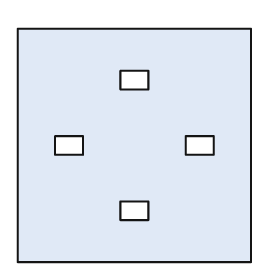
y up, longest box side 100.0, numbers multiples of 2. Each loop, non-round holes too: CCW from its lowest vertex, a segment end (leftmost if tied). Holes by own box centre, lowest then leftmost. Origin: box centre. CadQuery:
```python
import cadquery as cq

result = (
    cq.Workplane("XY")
    .moveTo(-50.0, -50.0)
    .lineTo(50.0, -50.0)
    .lineTo(50.0, 50.0)
    .lineTo(-50.0, 50.0)
    .close()
    .moveTo(-6.0, -32.0)
    .lineTo(6.0, -32.0)
    .lineTo(6.0, -24.0)
    .lineTo(-6.0, -24.0)
    .close()
    .moveTo(-34.0, -4.0)
    .lineTo(-22.0, -4.0)
    .lineTo(-22.0, 4.0)
    .lineTo(-34.0, 4.0)
    .close()
    .moveTo(22.0, -4.0)
    .lineTo(34.0, -4.0)
    .lineTo(34.0, 4.0)
    .lineTo(22.0, 4.0)
    .close()
    .moveTo(-6.0, 24.0)
    .lineTo(6.0, 24.0)
    .lineTo(6.0, 32.0)
    .lineTo(-6.0, 32.0)
    .close()
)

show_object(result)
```